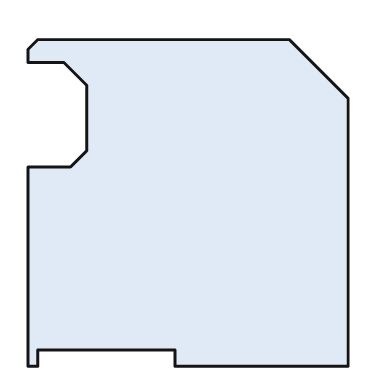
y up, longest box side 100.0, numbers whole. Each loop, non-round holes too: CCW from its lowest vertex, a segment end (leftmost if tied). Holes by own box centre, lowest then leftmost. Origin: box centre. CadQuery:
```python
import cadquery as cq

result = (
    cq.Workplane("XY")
    .moveTo(-49.0, -50.0)
    .lineTo(-46.0, -50.0)
    .lineTo(-46.0, -45.0)
    .lineTo(-4.0, -45.0)
    .lineTo(-4.0, -50.0)
    .lineTo(49.0, -50.0)
    .lineTo(49.0, 32.0)
    .lineTo(31.0, 50.0)
    .lineTo(-46.0, 50.0)
    .lineTo(-49.0, 47.0)
    .lineTo(-49.0, 43.0)
    .lineTo(-38.0, 43.0)
    .lineTo(-31.0, 36.0)
    .lineTo(-31.0, 16.0)
    .lineTo(-36.0, 11.0)
    .lineTo(-49.0, 11.0)
    .close()
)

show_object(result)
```